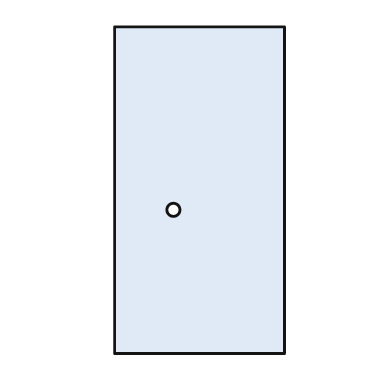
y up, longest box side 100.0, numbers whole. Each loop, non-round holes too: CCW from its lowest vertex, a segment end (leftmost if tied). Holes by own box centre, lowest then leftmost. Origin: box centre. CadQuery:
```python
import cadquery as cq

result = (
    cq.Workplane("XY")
    .moveTo(-26.0, -50.0)
    .lineTo(26.0, -50.0)
    .lineTo(26.0, 50.0)
    .lineTo(-26.0, 50.0)
    .close()
    .moveTo(-8.0, -6.0)
    .circle(2.0)
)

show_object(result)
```